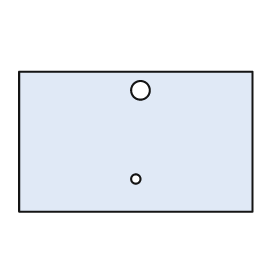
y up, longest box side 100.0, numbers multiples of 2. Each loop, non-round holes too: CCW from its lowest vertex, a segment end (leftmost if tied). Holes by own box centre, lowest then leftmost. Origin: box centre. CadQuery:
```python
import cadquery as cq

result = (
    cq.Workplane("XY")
    .moveTo(-50.0, -30.0)
    .lineTo(50.0, -30.0)
    .lineTo(50.0, 30.0)
    .lineTo(-50.0, 30.0)
    .close()
    .moveTo(0.0, -16.0)
    .circle(2.0)
    .moveTo(2.0, 22.0)
    .circle(4.0)
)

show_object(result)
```